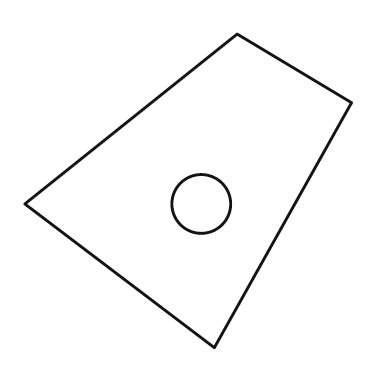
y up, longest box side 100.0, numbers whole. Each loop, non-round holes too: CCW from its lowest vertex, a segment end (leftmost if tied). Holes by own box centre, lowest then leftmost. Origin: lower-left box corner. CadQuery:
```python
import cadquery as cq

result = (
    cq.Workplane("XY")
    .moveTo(58.0, 0.0)
    .lineTo(100.0, 75.0)
    .lineTo(65.0, 96.0)
    .lineTo(0.0, 44.0)
    .close()
    .moveTo(54.0, 44.0)
    .circle(9.0)
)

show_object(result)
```